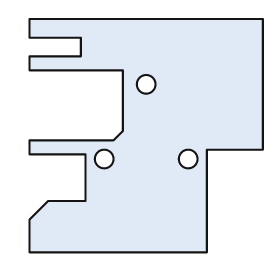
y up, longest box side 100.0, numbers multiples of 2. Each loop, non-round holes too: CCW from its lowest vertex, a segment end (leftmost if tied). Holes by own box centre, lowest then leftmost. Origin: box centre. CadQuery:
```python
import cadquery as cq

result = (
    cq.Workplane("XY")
    .moveTo(-50.0, -50.0)
    .lineTo(26.0, -50.0)
    .lineTo(26.0, -6.0)
    .lineTo(50.0, -6.0)
    .lineTo(50.0, 50.0)
    .lineTo(-50.0, 50.0)
    .lineTo(-50.0, 42.0)
    .lineTo(-28.0, 42.0)
    .lineTo(-28.0, 34.0)
    .lineTo(-50.0, 34.0)
    .lineTo(-50.0, 28.0)
    .lineTo(-10.0, 28.0)
    .lineTo(-10.0, 2.0)
    .lineTo(-14.0, -2.0)
    .lineTo(-50.0, -2.0)
    .lineTo(-50.0, -8.0)
    .lineTo(-26.0, -8.0)
    .lineTo(-26.0, -28.0)
    .lineTo(-42.0, -28.0)
    .lineTo(-50.0, -36.0)
    .close()
    .moveTo(-18.0, -10.0)
    .circle(4.0)
    .moveTo(18.0, -10.0)
    .circle(4.0)
    .moveTo(0.0, 22.0)
    .circle(4.0)
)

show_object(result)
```